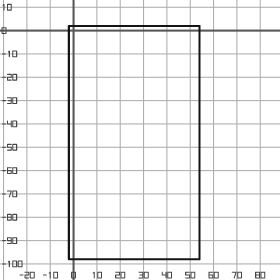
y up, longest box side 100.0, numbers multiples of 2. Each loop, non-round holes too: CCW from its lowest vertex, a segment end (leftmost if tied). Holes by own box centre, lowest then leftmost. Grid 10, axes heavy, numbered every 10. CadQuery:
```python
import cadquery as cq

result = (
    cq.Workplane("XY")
    .moveTo(-2.0, -98.0)
    .lineTo(54.0, -98.0)
    .lineTo(54.0, 2.0)
    .lineTo(-2.0, 2.0)
    .close()
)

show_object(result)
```